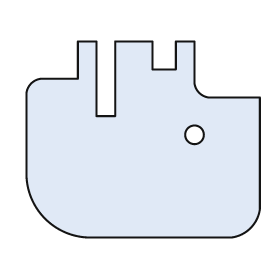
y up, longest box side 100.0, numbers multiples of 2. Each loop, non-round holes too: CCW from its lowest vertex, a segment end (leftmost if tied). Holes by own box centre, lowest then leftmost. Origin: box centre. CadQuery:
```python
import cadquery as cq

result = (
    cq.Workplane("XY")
    .moveTo(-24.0, -42.0)
    .lineTo(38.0, -42.0)
    .threePointArc((46.0, -38.0), (50.0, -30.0))
    .lineTo(50.0, 18.0)
    .lineTo(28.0, 18.0)
    .threePointArc((24.0, 20.0), (22.0, 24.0))
    .lineTo(22.0, 42.0)
    .lineTo(14.0, 42.0)
    .lineTo(14.0, 30.0)
    .lineTo(4.0, 30.0)
    .lineTo(4.0, 42.0)
    .lineTo(-12.0, 42.0)
    .lineTo(-12.0, 10.0)
    .lineTo(-20.0, 10.0)
    .lineTo(-20.0, 42.0)
    .lineTo(-28.0, 42.0)
    .lineTo(-28.0, 26.0)
    .lineTo(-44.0, 26.0)
    .threePointArc((-48.0, 24.0), (-50.0, 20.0))
    .lineTo(-50.0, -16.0)
    .threePointArc((-42.0, -34.0), (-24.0, -42.0))
    .close()
    .moveTo(22.0, 2.0)
    .circle(4.0)
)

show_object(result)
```